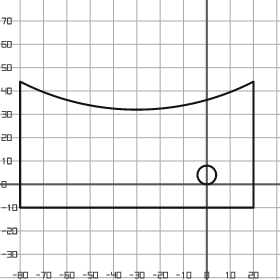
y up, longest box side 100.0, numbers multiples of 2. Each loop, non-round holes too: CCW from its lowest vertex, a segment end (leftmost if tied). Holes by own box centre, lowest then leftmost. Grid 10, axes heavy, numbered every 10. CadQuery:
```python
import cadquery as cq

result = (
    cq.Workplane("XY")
    .moveTo(-80.0, -10.0)
    .lineTo(20.0, -10.0)
    .lineTo(20.0, 44.0)
    .threePointArc((-30.0, 32.0), (-80.0, 44.0))
    .close()
    .moveTo(0.0, 4.0)
    .circle(4.0)
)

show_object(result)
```